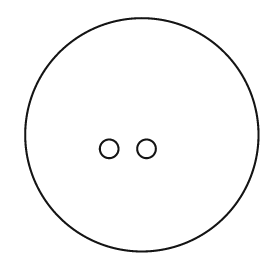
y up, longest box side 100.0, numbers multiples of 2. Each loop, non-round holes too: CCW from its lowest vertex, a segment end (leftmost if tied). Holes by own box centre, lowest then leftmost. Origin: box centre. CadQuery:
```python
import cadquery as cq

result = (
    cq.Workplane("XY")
    .moveTo(0.0, 0.0)
    .circle(50.0)
    .moveTo(-14.0, -6.0)
    .circle(4.0)
    .moveTo(2.0, -6.0)
    .circle(4.0)
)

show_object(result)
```